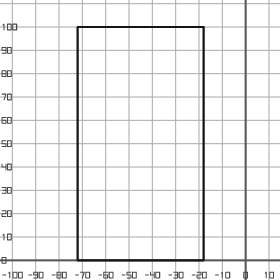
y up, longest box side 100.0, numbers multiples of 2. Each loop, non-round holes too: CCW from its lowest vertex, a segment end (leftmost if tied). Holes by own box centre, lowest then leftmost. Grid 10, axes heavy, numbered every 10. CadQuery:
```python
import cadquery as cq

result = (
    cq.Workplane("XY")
    .moveTo(-72.0, 0.0)
    .lineTo(-18.0, 0.0)
    .lineTo(-18.0, 100.0)
    .lineTo(-72.0, 100.0)
    .close()
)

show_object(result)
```